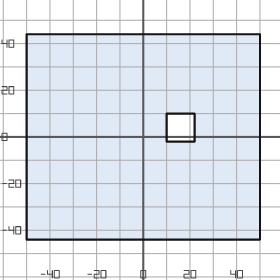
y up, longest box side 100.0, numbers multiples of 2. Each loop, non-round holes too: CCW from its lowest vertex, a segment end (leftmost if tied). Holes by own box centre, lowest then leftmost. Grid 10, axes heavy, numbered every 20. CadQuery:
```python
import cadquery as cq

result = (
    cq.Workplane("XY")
    .moveTo(-50.0, -44.0)
    .lineTo(50.0, -44.0)
    .lineTo(50.0, 44.0)
    .lineTo(-50.0, 44.0)
    .close()
    .moveTo(10.0, -2.0)
    .lineTo(22.0, -2.0)
    .lineTo(22.0, 10.0)
    .lineTo(10.0, 10.0)
    .close()
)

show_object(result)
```